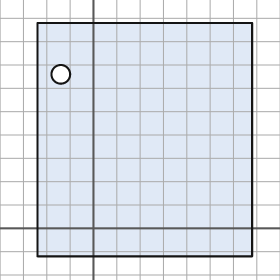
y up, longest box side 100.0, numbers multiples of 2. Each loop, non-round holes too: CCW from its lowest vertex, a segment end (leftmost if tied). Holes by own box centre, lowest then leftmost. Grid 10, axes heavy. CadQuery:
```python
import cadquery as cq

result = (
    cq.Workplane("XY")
    .moveTo(-24.0, -12.0)
    .lineTo(68.0, -12.0)
    .lineTo(68.0, 88.0)
    .lineTo(-24.0, 88.0)
    .close()
    .moveTo(-14.0, 66.0)
    .circle(4.0)
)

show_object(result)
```